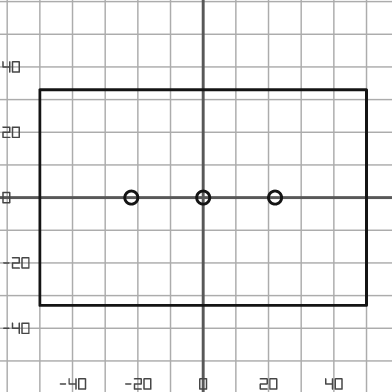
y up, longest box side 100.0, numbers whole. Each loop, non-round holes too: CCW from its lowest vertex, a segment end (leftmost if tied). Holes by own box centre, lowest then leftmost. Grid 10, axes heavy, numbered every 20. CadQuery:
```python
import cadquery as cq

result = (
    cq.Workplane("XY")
    .moveTo(-50.0, -33.0)
    .lineTo(50.0, -33.0)
    .lineTo(50.0, 33.0)
    .lineTo(-50.0, 33.0)
    .close()
    .moveTo(-22.0, 0.0)
    .circle(2.0)
    .moveTo(0.0, 0.0)
    .circle(2.0)
    .moveTo(22.0, 0.0)
    .circle(2.0)
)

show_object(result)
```